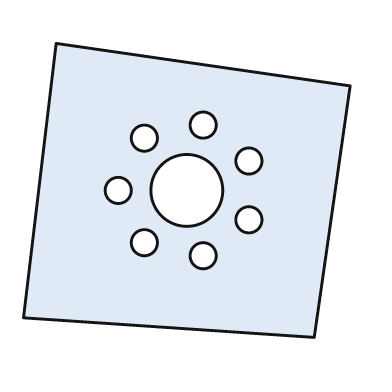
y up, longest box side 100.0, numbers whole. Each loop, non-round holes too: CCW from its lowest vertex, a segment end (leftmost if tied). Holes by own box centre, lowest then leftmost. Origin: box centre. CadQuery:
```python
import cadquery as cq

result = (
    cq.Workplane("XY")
    .moveTo(39.0, -45.0)
    .lineTo(50.0, 32.0)
    .lineTo(-40.0, 45.0)
    .lineTo(-50.0, -39.0)
    .close()
    .moveTo(5.0, -20.0)
    .circle(4.0)
    .moveTo(-13.0, -16.0)
    .circle(4.0)
    .moveTo(19.0, -9.0)
    .circle(4.0)
    .moveTo(-21.0, 0.0)
    .circle(4.0)
    .moveTo(0.0, 0.0)
    .circle(11.0)
    .moveTo(19.0, 9.0)
    .circle(4.0)
    .moveTo(-13.0, 16.0)
    .circle(4.0)
    .moveTo(5.0, 20.0)
    .circle(4.0)
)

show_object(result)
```